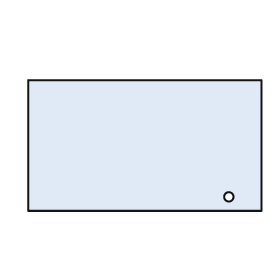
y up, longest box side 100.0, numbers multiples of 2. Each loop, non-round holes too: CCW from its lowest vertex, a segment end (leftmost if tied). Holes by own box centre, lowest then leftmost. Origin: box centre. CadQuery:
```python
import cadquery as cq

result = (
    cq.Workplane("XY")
    .moveTo(-50.0, -28.0)
    .lineTo(50.0, -28.0)
    .lineTo(50.0, 28.0)
    .lineTo(-50.0, 28.0)
    .close()
    .moveTo(36.0, -22.0)
    .circle(2.0)
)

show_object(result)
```